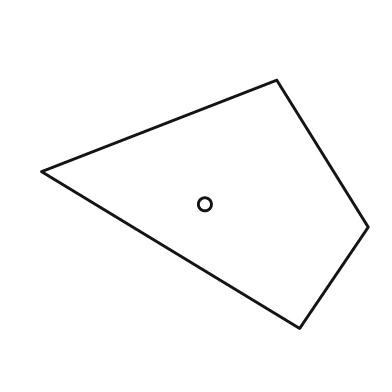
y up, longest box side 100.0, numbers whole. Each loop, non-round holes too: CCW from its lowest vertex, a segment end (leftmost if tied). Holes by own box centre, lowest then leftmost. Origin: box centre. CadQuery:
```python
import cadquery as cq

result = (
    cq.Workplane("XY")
    .moveTo(29.0, -38.0)
    .lineTo(50.0, -7.0)
    .lineTo(22.0, 38.0)
    .lineTo(-50.0, 10.0)
    .close()
    .moveTo(0.0, 0.0)
    .circle(2.0)
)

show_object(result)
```